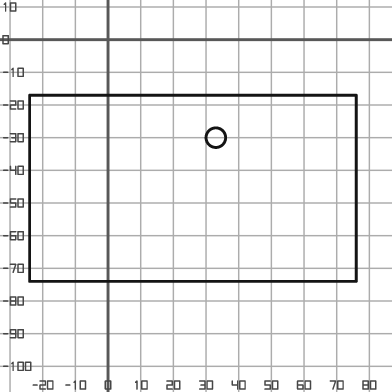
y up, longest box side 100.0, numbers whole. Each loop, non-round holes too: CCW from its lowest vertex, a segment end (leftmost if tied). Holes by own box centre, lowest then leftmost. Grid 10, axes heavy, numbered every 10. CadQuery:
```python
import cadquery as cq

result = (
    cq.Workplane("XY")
    .moveTo(-24.0, -74.0)
    .lineTo(76.0, -74.0)
    .lineTo(76.0, -17.0)
    .lineTo(-24.0, -17.0)
    .close()
    .moveTo(33.0, -30.0)
    .circle(3.0)
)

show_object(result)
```